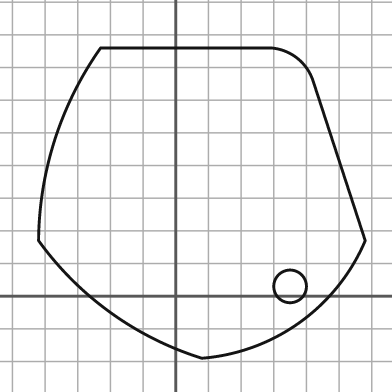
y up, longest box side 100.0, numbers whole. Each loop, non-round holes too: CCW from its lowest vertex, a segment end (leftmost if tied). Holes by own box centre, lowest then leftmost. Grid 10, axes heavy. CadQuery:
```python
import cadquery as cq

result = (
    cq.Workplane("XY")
    .moveTo(8.0, -19.0)
    .threePointArc((38.0, -8.0), (58.0, 17.0))
    .lineTo(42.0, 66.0)
    .threePointArc((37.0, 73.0), (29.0, 76.0))
    .lineTo(-23.0, 76.0)
    .threePointArc((-37.0, 48.0), (-42.0, 17.0))
    .threePointArc((-20.0, -5.0), (8.0, -19.0))
    .close()
    .moveTo(35.0, 3.0)
    .circle(5.0)
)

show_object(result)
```